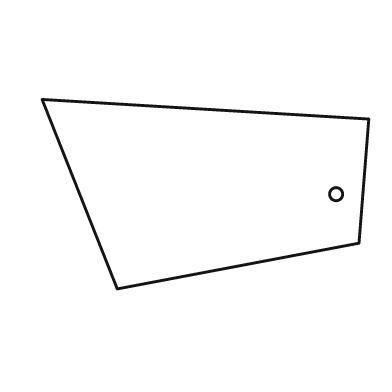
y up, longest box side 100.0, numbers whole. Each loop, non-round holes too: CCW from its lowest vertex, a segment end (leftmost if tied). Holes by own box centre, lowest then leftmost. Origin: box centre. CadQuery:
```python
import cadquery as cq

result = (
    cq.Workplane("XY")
    .moveTo(-27.0, -29.0)
    .lineTo(47.0, -15.0)
    .lineTo(50.0, 23.0)
    .lineTo(-50.0, 29.0)
    .close()
    .moveTo(40.0, 0.0)
    .circle(2.0)
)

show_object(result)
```